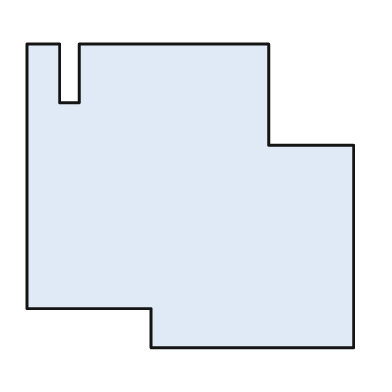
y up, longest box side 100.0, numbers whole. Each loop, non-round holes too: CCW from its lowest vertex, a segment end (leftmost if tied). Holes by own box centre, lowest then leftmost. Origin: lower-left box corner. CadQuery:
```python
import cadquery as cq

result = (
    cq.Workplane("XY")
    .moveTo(38.0, 0.0)
    .lineTo(100.0, 0.0)
    .lineTo(100.0, 62.0)
    .lineTo(74.0, 62.0)
    .lineTo(74.0, 93.0)
    .lineTo(16.0, 93.0)
    .lineTo(16.0, 75.0)
    .lineTo(10.0, 75.0)
    .lineTo(10.0, 93.0)
    .lineTo(0.0, 93.0)
    .lineTo(0.0, 12.0)
    .lineTo(38.0, 12.0)
    .close()
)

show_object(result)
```